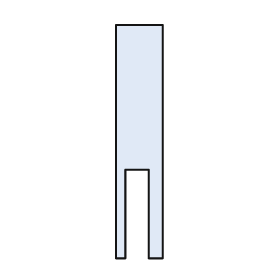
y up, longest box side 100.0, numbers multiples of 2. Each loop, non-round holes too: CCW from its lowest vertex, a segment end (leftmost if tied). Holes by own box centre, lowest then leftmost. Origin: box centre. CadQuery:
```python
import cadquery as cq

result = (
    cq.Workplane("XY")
    .moveTo(-10.0, -50.0)
    .lineTo(-6.0, -50.0)
    .lineTo(-6.0, -12.0)
    .lineTo(4.0, -12.0)
    .lineTo(4.0, -50.0)
    .lineTo(10.0, -50.0)
    .lineTo(10.0, 50.0)
    .lineTo(-10.0, 50.0)
    .close()
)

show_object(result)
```